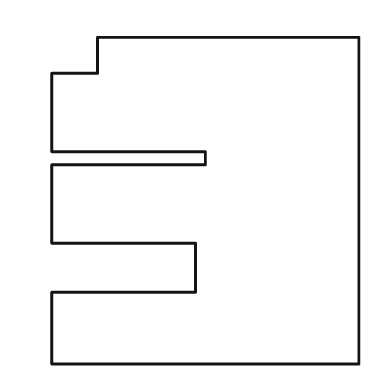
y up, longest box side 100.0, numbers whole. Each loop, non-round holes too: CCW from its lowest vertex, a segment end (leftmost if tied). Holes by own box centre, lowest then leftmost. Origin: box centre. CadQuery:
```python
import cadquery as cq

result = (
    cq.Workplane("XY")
    .moveTo(-47.0, -50.0)
    .lineTo(47.0, -50.0)
    .lineTo(47.0, 50.0)
    .lineTo(-33.0, 50.0)
    .lineTo(-33.0, 39.0)
    .lineTo(-47.0, 39.0)
    .lineTo(-47.0, 15.0)
    .lineTo(0.0, 15.0)
    .lineTo(0.0, 11.0)
    .lineTo(-47.0, 11.0)
    .lineTo(-47.0, -13.0)
    .lineTo(-3.0, -13.0)
    .lineTo(-3.0, -28.0)
    .lineTo(-47.0, -28.0)
    .close()
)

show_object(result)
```